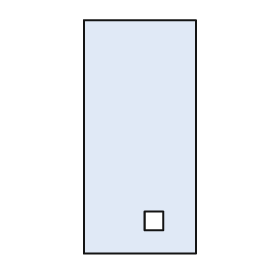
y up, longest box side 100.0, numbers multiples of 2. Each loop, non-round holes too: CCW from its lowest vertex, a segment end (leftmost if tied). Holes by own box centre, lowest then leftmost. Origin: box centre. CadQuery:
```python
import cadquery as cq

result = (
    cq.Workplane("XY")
    .moveTo(-24.0, -50.0)
    .lineTo(24.0, -50.0)
    .lineTo(24.0, 50.0)
    .lineTo(-24.0, 50.0)
    .close()
    .moveTo(2.0, -40.0)
    .lineTo(10.0, -40.0)
    .lineTo(10.0, -32.0)
    .lineTo(2.0, -32.0)
    .close()
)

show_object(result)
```